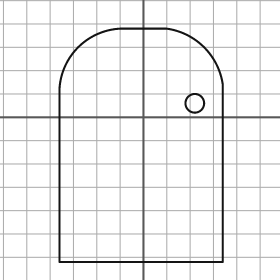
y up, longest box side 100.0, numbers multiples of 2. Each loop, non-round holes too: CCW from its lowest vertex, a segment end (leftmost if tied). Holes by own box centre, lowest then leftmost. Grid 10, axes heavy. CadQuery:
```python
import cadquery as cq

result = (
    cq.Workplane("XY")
    .moveTo(-36.0, -62.0)
    .lineTo(34.0, -62.0)
    .lineTo(34.0, 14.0)
    .threePointArc((26.0, 30.0), (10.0, 38.0))
    .lineTo(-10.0, 38.0)
    .threePointArc((-28.0, 30.0), (-36.0, 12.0))
    .close()
    .moveTo(22.0, 6.0)
    .circle(4.0)
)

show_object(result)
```